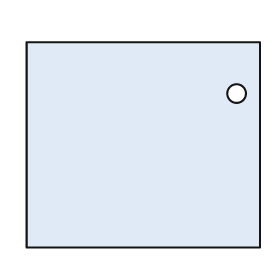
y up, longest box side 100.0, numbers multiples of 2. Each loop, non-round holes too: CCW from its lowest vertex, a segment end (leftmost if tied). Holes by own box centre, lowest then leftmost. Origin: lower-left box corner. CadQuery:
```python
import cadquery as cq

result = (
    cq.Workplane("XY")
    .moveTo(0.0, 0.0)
    .lineTo(100.0, 0.0)
    .lineTo(100.0, 88.0)
    .lineTo(0.0, 88.0)
    .close()
    .moveTo(90.0, 66.0)
    .circle(4.0)
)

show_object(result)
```